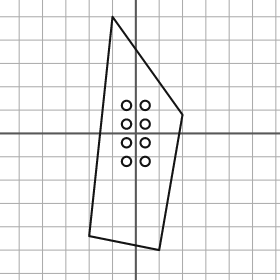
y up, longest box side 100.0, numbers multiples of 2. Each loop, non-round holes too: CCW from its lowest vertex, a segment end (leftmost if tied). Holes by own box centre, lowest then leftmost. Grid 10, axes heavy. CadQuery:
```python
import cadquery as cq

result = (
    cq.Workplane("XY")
    .moveTo(10.0, -50.0)
    .lineTo(20.0, 8.0)
    .lineTo(-10.0, 50.0)
    .lineTo(-20.0, -44.0)
    .close()
    .moveTo(-4.0, -12.0)
    .circle(2.0)
    .moveTo(4.0, -12.0)
    .circle(2.0)
    .moveTo(-4.0, -4.0)
    .circle(2.0)
    .moveTo(4.0, -4.0)
    .circle(2.0)
    .moveTo(-4.0, 4.0)
    .circle(2.0)
    .moveTo(4.0, 4.0)
    .circle(2.0)
    .moveTo(-4.0, 12.0)
    .circle(2.0)
    .moveTo(4.0, 12.0)
    .circle(2.0)
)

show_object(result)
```